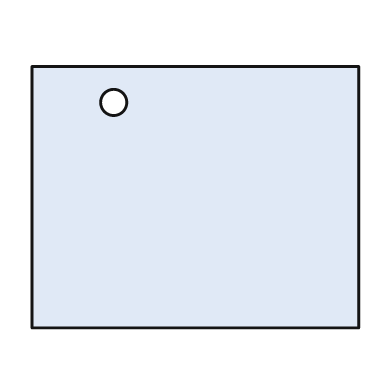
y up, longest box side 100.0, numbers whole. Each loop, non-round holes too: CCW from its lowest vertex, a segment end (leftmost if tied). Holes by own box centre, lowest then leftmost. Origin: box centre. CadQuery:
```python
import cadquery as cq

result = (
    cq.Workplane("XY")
    .moveTo(-50.0, -40.0)
    .lineTo(50.0, -40.0)
    .lineTo(50.0, 40.0)
    .lineTo(-50.0, 40.0)
    .close()
    .moveTo(-25.0, 29.0)
    .circle(4.0)
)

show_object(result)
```